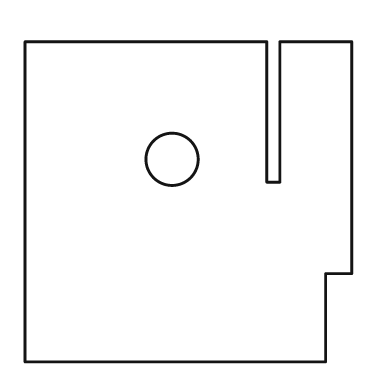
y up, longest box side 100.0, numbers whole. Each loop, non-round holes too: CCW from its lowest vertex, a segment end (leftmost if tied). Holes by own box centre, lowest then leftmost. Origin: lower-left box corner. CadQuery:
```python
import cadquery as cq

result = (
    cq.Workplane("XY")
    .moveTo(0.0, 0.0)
    .lineTo(92.0, 0.0)
    .lineTo(92.0, 27.0)
    .lineTo(100.0, 27.0)
    .lineTo(100.0, 98.0)
    .lineTo(78.0, 98.0)
    .lineTo(78.0, 55.0)
    .lineTo(74.0, 55.0)
    .lineTo(74.0, 98.0)
    .lineTo(0.0, 98.0)
    .close()
    .moveTo(45.0, 62.0)
    .circle(8.0)
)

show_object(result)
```